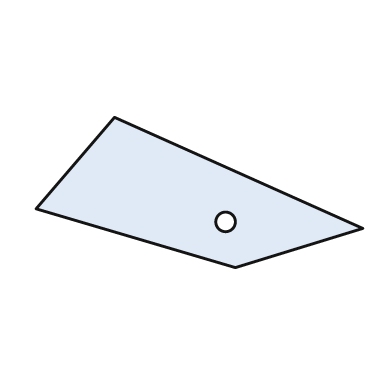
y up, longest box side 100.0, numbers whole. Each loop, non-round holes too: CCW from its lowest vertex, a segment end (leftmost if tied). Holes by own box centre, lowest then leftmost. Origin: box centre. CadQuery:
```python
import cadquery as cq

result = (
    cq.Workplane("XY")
    .moveTo(11.0, -23.0)
    .lineTo(50.0, -11.0)
    .lineTo(-26.0, 23.0)
    .lineTo(-50.0, -5.0)
    .close()
    .moveTo(8.0, -9.0)
    .circle(3.0)
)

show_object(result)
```